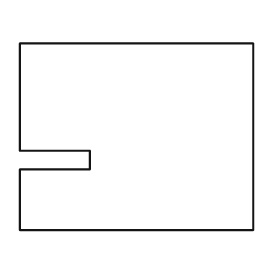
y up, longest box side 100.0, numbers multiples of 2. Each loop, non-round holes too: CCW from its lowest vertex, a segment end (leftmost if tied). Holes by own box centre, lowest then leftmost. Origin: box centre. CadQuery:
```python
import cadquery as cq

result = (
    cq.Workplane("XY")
    .moveTo(-50.0, -40.0)
    .lineTo(50.0, -40.0)
    .lineTo(50.0, 40.0)
    .lineTo(-50.0, 40.0)
    .lineTo(-50.0, -6.0)
    .lineTo(-20.0, -6.0)
    .lineTo(-20.0, -14.0)
    .lineTo(-50.0, -14.0)
    .close()
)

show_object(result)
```